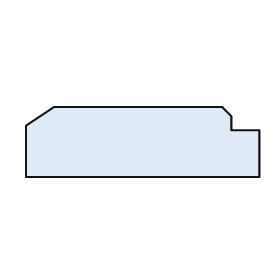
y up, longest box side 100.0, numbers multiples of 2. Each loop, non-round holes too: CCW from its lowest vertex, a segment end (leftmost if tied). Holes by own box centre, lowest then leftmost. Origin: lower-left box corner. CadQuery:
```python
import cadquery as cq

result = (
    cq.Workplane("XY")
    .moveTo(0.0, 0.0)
    .lineTo(100.0, 0.0)
    .lineTo(100.0, 20.0)
    .lineTo(88.0, 20.0)
    .lineTo(88.0, 26.0)
    .lineTo(84.0, 30.0)
    .lineTo(12.0, 30.0)
    .lineTo(0.0, 22.0)
    .close()
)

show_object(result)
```